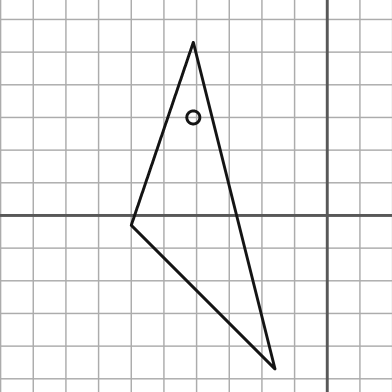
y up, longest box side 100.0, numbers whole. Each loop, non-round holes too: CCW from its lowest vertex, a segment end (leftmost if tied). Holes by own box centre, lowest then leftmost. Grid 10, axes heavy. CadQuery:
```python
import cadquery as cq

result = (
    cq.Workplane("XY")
    .moveTo(-16.0, -47.0)
    .lineTo(-41.0, 53.0)
    .lineTo(-60.0, -3.0)
    .close()
    .moveTo(-41.0, 30.0)
    .circle(2.0)
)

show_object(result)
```